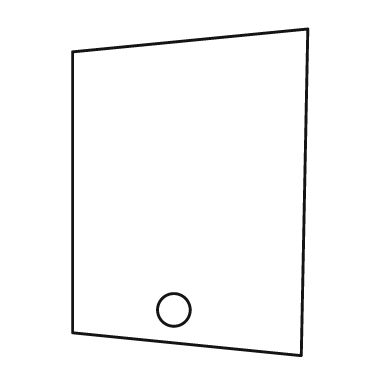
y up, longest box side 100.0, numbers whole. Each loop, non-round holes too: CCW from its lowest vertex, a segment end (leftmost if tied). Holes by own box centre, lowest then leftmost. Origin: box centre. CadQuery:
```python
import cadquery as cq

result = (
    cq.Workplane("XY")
    .moveTo(34.0, -50.0)
    .lineTo(36.0, 50.0)
    .lineTo(-36.0, 43.0)
    .lineTo(-36.0, -43.0)
    .close()
    .moveTo(-5.0, -36.0)
    .circle(5.0)
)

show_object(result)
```